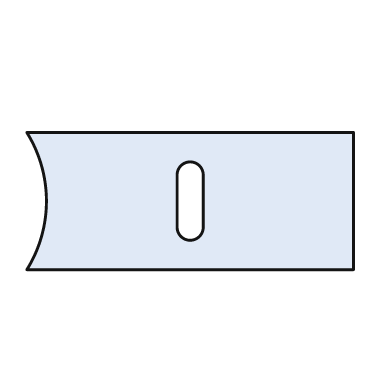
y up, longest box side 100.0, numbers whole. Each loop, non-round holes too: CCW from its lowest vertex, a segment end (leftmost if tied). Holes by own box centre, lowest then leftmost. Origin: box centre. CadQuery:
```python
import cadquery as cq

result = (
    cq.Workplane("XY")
    .moveTo(-50.0, -21.0)
    .lineTo(50.0, -21.0)
    .lineTo(50.0, 21.0)
    .lineTo(-50.0, 21.0)
    .threePointArc((-44.0, 0.0), (-50.0, -21.0))
    .close()
    .moveTo(-4.0, -8.0)
    .threePointArc((0.0, -12.0), (4.0, -8.0))
    .lineTo(4.0, 8.0)
    .threePointArc((0.0, 12.0), (-4.0, 8.0))
    .close()
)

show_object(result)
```